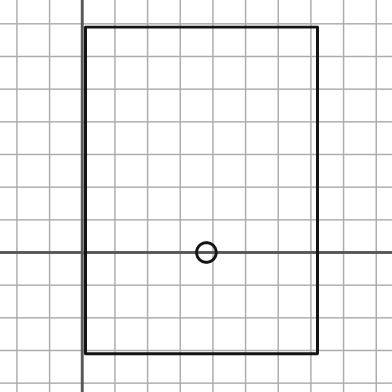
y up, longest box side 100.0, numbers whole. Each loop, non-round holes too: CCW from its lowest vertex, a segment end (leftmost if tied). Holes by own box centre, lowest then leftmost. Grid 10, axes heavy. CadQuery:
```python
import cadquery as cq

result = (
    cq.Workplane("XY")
    .moveTo(1.0, -31.0)
    .lineTo(72.0, -31.0)
    .lineTo(72.0, 69.0)
    .lineTo(1.0, 69.0)
    .close()
    .moveTo(38.0, 0.0)
    .circle(3.0)
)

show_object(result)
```